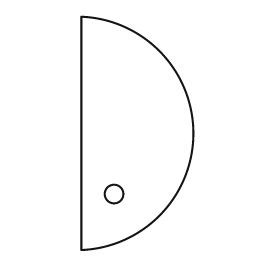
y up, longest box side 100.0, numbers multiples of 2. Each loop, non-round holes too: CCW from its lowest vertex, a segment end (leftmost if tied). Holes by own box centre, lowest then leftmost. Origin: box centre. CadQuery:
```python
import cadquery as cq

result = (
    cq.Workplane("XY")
    .moveTo(-24.0, -50.0)
    .threePointArc((24.0, 0.0), (-24.0, 50.0))
    .close()
    .moveTo(-10.0, -26.0)
    .circle(4.0)
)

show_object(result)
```